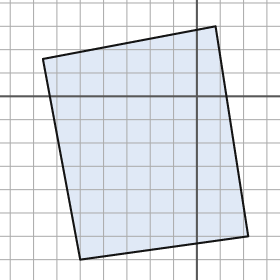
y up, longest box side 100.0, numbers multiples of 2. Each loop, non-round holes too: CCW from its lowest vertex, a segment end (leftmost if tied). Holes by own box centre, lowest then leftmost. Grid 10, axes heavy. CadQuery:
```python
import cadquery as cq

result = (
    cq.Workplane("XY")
    .moveTo(-50.0, -70.0)
    .lineTo(22.0, -60.0)
    .lineTo(8.0, 30.0)
    .lineTo(-66.0, 16.0)
    .close()
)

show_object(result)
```